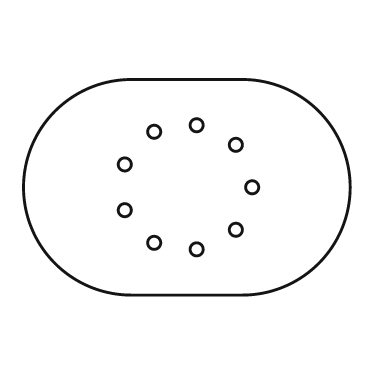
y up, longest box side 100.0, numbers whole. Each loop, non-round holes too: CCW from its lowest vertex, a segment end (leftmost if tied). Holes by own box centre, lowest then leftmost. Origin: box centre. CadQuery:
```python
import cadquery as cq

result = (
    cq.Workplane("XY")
    .moveTo(-17.0, -33.0)
    .lineTo(17.0, -33.0)
    .threePointArc((50.0, 0.0), (17.0, 33.0))
    .lineTo(-17.0, 33.0)
    .threePointArc((-50.0, 0.0), (-17.0, -33.0))
    .close()
    .moveTo(3.0, -19.0)
    .circle(2.0)
    .moveTo(-10.0, -17.0)
    .circle(2.0)
    .moveTo(15.0, -13.0)
    .circle(2.0)
    .moveTo(-19.0, -7.0)
    .circle(2.0)
    .moveTo(20.0, 0.0)
    .circle(2.0)
    .moveTo(-19.0, 7.0)
    .circle(2.0)
    .moveTo(15.0, 13.0)
    .circle(2.0)
    .moveTo(-10.0, 17.0)
    .circle(2.0)
    .moveTo(3.0, 19.0)
    .circle(2.0)
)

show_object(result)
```